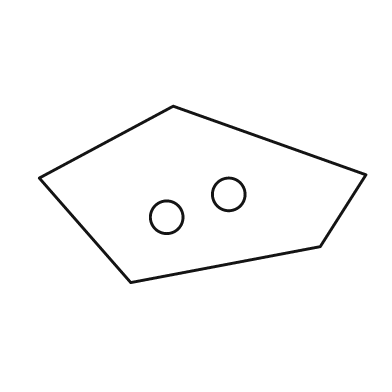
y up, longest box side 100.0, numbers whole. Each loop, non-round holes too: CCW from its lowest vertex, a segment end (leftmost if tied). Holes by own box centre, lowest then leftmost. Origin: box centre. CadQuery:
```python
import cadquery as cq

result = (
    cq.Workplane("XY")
    .moveTo(-22.0, -27.0)
    .lineTo(36.0, -16.0)
    .lineTo(50.0, 6.0)
    .lineTo(-9.0, 27.0)
    .lineTo(-50.0, 5.0)
    .close()
    .moveTo(-11.0, -7.0)
    .circle(5.0)
    .moveTo(8.0, 0.0)
    .circle(5.0)
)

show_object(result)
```